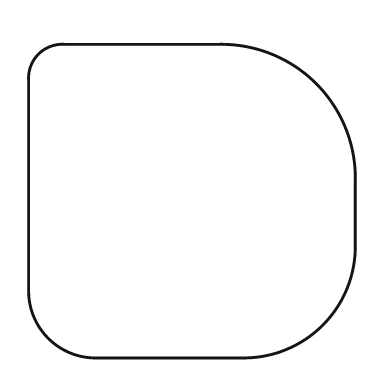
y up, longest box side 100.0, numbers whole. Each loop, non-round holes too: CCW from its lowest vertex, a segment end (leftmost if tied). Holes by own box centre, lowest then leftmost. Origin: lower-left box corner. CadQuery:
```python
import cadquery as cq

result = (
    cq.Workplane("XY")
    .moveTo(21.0, 0.0)
    .lineTo(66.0, 0.0)
    .threePointArc((90.0, 10.0), (100.0, 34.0))
    .lineTo(100.0, 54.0)
    .threePointArc((88.0, 84.0), (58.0, 96.0))
    .lineTo(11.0, 96.0)
    .threePointArc((3.0, 93.0), (0.0, 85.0))
    .lineTo(0.0, 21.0)
    .threePointArc((6.0, 6.0), (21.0, 0.0))
    .close()
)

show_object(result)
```